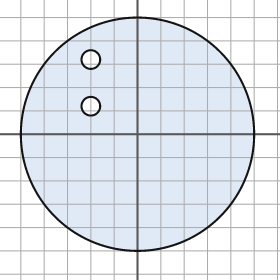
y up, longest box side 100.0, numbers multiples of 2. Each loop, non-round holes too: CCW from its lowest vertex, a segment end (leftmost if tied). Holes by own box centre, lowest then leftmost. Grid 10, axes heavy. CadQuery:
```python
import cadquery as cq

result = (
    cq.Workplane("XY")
    .moveTo(0.0, 0.0)
    .circle(50.0)
    .moveTo(-20.0, 12.0)
    .circle(4.0)
    .moveTo(-20.0, 32.0)
    .circle(4.0)
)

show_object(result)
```